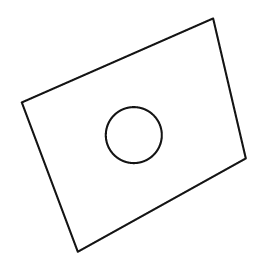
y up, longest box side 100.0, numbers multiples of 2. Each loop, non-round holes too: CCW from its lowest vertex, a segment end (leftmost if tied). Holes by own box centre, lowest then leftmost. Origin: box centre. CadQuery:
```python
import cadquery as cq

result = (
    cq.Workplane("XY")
    .moveTo(-24.0, -50.0)
    .lineTo(48.0, -10.0)
    .lineTo(34.0, 50.0)
    .lineTo(-48.0, 14.0)
    .close()
    .moveTo(0.0, 0.0)
    .circle(12.0)
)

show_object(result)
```